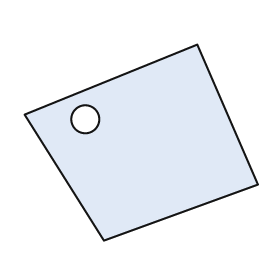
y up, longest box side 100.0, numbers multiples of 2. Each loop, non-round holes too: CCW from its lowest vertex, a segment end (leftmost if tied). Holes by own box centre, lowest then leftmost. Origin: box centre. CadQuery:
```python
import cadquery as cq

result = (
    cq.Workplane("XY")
    .moveTo(-16.0, -42.0)
    .lineTo(50.0, -18.0)
    .lineTo(24.0, 42.0)
    .lineTo(-50.0, 12.0)
    .close()
    .moveTo(-24.0, 10.0)
    .circle(6.0)
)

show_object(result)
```